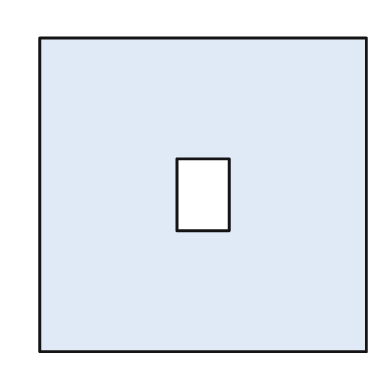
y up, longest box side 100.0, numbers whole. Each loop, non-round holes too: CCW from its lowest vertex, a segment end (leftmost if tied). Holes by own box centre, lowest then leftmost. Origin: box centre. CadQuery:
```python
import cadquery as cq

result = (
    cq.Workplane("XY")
    .moveTo(-50.0, -48.0)
    .lineTo(50.0, -48.0)
    .lineTo(50.0, 48.0)
    .lineTo(-50.0, 48.0)
    .close()
    .moveTo(-8.0, -11.0)
    .lineTo(8.0, -11.0)
    .lineTo(8.0, 11.0)
    .lineTo(-8.0, 11.0)
    .close()
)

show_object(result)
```